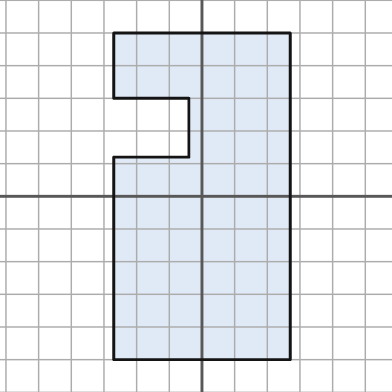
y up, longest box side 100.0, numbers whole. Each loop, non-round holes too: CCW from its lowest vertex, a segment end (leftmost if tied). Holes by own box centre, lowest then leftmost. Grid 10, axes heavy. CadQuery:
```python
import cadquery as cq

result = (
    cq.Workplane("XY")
    .moveTo(-27.0, -50.0)
    .lineTo(27.0, -50.0)
    .lineTo(27.0, 50.0)
    .lineTo(-27.0, 50.0)
    .lineTo(-27.0, 30.0)
    .lineTo(-4.0, 30.0)
    .lineTo(-4.0, 12.0)
    .lineTo(-27.0, 12.0)
    .close()
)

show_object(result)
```